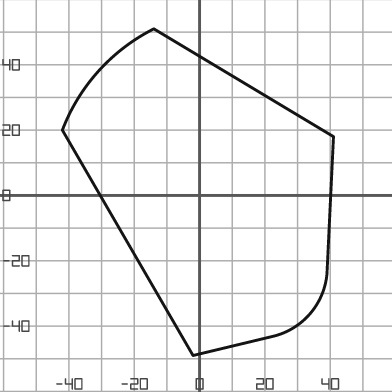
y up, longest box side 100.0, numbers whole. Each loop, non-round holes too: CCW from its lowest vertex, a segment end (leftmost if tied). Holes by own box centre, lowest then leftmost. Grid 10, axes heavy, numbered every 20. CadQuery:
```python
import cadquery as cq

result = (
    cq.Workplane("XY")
    .moveTo(-2.0, -49.0)
    .lineTo(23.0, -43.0)
    .threePointArc((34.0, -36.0), (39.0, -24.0))
    .lineTo(41.0, 18.0)
    .lineTo(-14.0, 51.0)
    .threePointArc((-31.0, 38.0), (-42.0, 20.0))
    .close()
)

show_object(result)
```